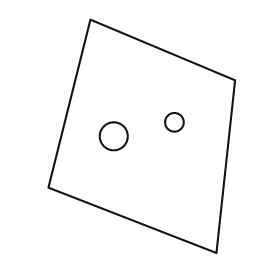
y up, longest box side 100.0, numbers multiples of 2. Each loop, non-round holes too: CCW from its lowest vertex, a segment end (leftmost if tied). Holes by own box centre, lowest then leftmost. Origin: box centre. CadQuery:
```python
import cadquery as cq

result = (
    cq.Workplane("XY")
    .moveTo(32.0, -50.0)
    .lineTo(40.0, 24.0)
    .lineTo(-22.0, 50.0)
    .lineTo(-40.0, -22.0)
    .close()
    .moveTo(-12.0, 0.0)
    .circle(6.0)
    .moveTo(14.0, 6.0)
    .circle(4.0)
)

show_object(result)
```